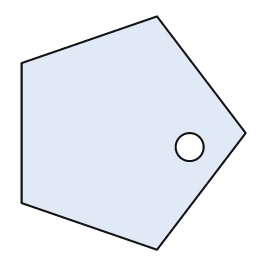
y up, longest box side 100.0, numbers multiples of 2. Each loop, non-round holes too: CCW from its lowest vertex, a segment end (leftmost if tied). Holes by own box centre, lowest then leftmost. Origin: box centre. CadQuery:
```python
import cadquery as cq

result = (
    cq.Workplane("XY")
    .moveTo(10.0, -50.0)
    .lineTo(48.0, 0.0)
    .lineTo(10.0, 50.0)
    .lineTo(-48.0, 30.0)
    .lineTo(-48.0, -30.0)
    .close()
    .moveTo(24.0, -6.0)
    .circle(6.0)
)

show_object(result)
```